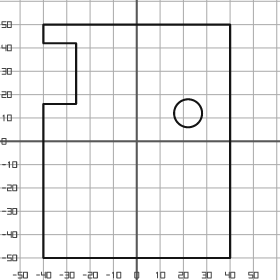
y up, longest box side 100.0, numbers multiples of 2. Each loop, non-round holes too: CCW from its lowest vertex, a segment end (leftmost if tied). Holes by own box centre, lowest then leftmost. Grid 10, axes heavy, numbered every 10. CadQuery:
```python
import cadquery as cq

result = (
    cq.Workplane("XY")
    .moveTo(-40.0, -50.0)
    .lineTo(40.0, -50.0)
    .lineTo(40.0, 50.0)
    .lineTo(-40.0, 50.0)
    .lineTo(-40.0, 42.0)
    .lineTo(-26.0, 42.0)
    .lineTo(-26.0, 16.0)
    .lineTo(-40.0, 16.0)
    .close()
    .moveTo(22.0, 12.0)
    .circle(6.0)
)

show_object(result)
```